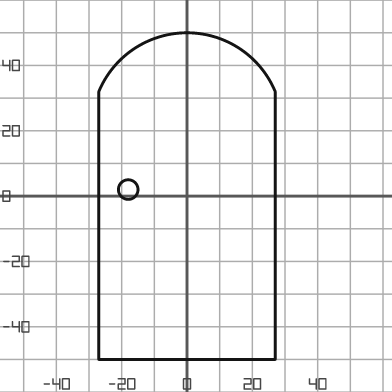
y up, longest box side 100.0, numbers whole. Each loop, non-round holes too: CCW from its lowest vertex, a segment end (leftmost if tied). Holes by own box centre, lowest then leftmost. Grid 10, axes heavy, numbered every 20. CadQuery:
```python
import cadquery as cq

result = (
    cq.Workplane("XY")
    .moveTo(-27.0, -50.0)
    .lineTo(27.0, -50.0)
    .lineTo(27.0, 32.0)
    .threePointArc((0.0, 50.0), (-27.0, 32.0))
    .close()
    .moveTo(-18.0, 2.0)
    .circle(3.0)
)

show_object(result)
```